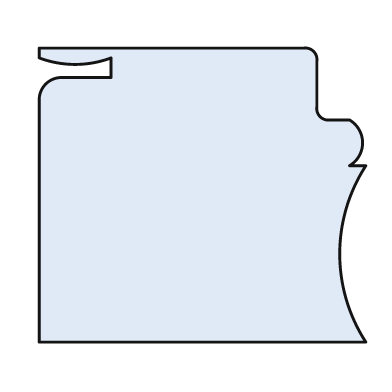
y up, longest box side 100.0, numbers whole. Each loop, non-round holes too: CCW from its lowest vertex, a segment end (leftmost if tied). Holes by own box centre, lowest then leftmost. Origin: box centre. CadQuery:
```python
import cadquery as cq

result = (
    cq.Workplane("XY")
    .moveTo(-50.0, -45.0)
    .lineTo(50.0, -45.0)
    .threePointArc((42.0, -18.0), (50.0, 9.0))
    .lineTo(45.0, 9.0)
    .threePointArc((49.0, 16.0), (45.0, 23.0))
    .lineTo(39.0, 23.0)
    .threePointArc((36.0, 24.0), (35.0, 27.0))
    .lineTo(35.0, 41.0)
    .threePointArc((34.0, 44.0), (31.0, 45.0))
    .lineTo(-50.0, 45.0)
    .lineTo(-50.0, 42.0)
    .threePointArc((-39.0, 40.0), (-28.0, 42.0))
    .lineTo(-28.0, 36.0)
    .lineTo(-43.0, 36.0)
    .threePointArc((-48.0, 34.0), (-50.0, 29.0))
    .close()
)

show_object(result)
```